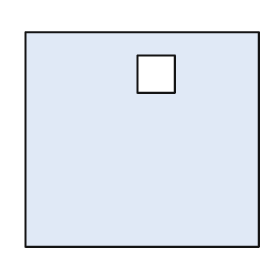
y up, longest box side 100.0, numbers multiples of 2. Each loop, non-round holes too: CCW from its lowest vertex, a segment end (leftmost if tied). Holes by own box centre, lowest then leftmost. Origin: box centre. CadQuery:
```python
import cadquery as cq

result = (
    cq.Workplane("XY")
    .moveTo(-50.0, -46.0)
    .lineTo(50.0, -46.0)
    .lineTo(50.0, 46.0)
    .lineTo(-50.0, 46.0)
    .close()
    .moveTo(-2.0, 20.0)
    .lineTo(14.0, 20.0)
    .lineTo(14.0, 36.0)
    .lineTo(-2.0, 36.0)
    .close()
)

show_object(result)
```